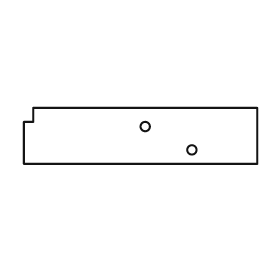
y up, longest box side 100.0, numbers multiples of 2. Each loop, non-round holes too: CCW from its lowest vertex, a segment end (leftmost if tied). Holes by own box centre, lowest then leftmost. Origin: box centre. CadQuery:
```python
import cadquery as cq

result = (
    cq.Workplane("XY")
    .moveTo(-50.0, -12.0)
    .lineTo(50.0, -12.0)
    .lineTo(50.0, 12.0)
    .lineTo(-46.0, 12.0)
    .lineTo(-46.0, 6.0)
    .lineTo(-50.0, 6.0)
    .close()
    .moveTo(22.0, -6.0)
    .circle(2.0)
    .moveTo(2.0, 4.0)
    .circle(2.0)
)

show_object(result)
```